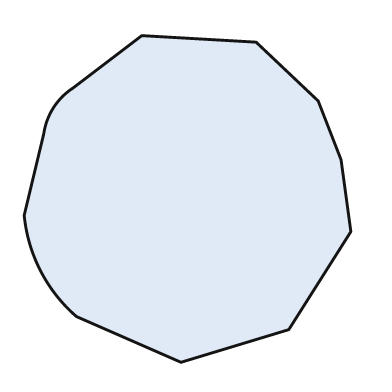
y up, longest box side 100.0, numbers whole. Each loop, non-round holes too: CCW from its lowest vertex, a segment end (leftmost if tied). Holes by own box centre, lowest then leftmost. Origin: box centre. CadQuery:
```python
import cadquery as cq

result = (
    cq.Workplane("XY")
    .moveTo(-2.0, -50.0)
    .lineTo(31.0, -40.0)
    .lineTo(50.0, -10.0)
    .lineTo(47.0, 12.0)
    .lineTo(40.0, 30.0)
    .lineTo(21.0, 48.0)
    .lineTo(-14.0, 50.0)
    .lineTo(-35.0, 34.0)
    .threePointArc((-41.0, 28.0), (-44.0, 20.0))
    .lineTo(-50.0, -5.0)
    .threePointArc((-45.0, -22.0), (-34.0, -36.0))
    .close()
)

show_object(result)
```